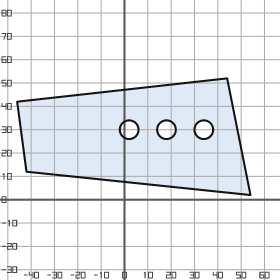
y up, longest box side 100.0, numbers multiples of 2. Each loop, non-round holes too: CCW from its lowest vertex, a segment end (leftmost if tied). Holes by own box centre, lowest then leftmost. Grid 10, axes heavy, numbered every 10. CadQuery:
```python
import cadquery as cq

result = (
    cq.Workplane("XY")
    .moveTo(54.0, 2.0)
    .lineTo(44.0, 52.0)
    .lineTo(-46.0, 42.0)
    .lineTo(-42.0, 12.0)
    .close()
    .moveTo(2.0, 30.0)
    .circle(4.0)
    .moveTo(18.0, 30.0)
    .circle(4.0)
    .moveTo(34.0, 30.0)
    .circle(4.0)
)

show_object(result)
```